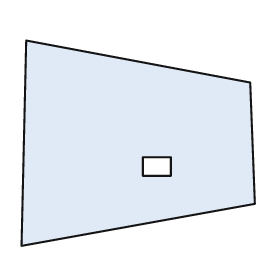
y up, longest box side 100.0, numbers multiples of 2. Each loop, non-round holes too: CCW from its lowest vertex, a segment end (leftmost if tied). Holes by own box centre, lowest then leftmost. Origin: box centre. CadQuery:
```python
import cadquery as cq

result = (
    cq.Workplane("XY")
    .moveTo(-50.0, -44.0)
    .lineTo(50.0, -26.0)
    .lineTo(48.0, 26.0)
    .lineTo(-48.0, 44.0)
    .close()
    .moveTo(2.0, -14.0)
    .lineTo(14.0, -14.0)
    .lineTo(14.0, -6.0)
    .lineTo(2.0, -6.0)
    .close()
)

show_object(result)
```